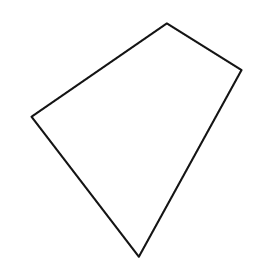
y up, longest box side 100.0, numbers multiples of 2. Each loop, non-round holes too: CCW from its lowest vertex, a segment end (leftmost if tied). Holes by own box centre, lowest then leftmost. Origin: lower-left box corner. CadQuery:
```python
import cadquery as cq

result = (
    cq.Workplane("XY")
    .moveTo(46.0, 0.0)
    .lineTo(90.0, 80.0)
    .lineTo(58.0, 100.0)
    .lineTo(0.0, 60.0)
    .close()
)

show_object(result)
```